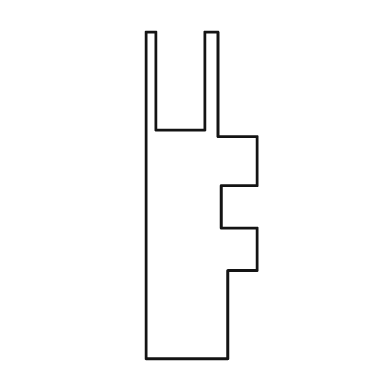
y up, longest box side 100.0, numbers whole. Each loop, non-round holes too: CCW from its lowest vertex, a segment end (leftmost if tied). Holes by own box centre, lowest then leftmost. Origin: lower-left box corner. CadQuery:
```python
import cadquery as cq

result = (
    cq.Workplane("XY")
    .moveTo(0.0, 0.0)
    .lineTo(25.0, 0.0)
    .lineTo(25.0, 27.0)
    .lineTo(34.0, 27.0)
    .lineTo(34.0, 40.0)
    .lineTo(23.0, 40.0)
    .lineTo(23.0, 53.0)
    .lineTo(34.0, 53.0)
    .lineTo(34.0, 68.0)
    .lineTo(22.0, 68.0)
    .lineTo(22.0, 100.0)
    .lineTo(18.0, 100.0)
    .lineTo(18.0, 70.0)
    .lineTo(3.0, 70.0)
    .lineTo(3.0, 100.0)
    .lineTo(0.0, 100.0)
    .close()
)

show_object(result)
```